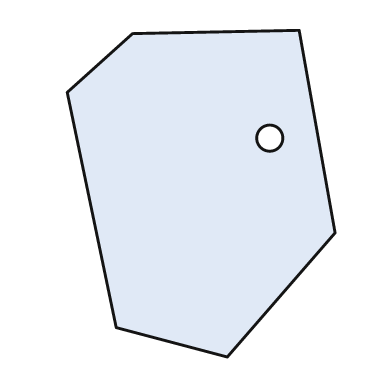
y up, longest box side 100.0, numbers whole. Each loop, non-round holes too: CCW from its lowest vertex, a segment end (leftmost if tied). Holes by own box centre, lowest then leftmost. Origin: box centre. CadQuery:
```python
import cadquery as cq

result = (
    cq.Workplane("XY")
    .moveTo(8.0, -50.0)
    .lineTo(41.0, -12.0)
    .lineTo(30.0, 50.0)
    .lineTo(-21.0, 49.0)
    .lineTo(-41.0, 31.0)
    .lineTo(-26.0, -41.0)
    .close()
    .moveTo(21.0, 17.0)
    .circle(4.0)
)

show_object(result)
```